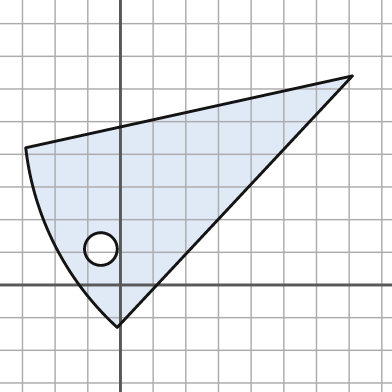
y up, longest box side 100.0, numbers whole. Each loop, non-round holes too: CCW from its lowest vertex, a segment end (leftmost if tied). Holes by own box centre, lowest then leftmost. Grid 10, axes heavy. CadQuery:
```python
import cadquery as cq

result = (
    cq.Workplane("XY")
    .moveTo(-1.0, -13.0)
    .lineTo(71.0, 64.0)
    .lineTo(-29.0, 42.0)
    .threePointArc((-20.0, 12.0), (-1.0, -13.0))
    .close()
    .moveTo(-6.0, 11.0)
    .circle(5.0)
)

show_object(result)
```